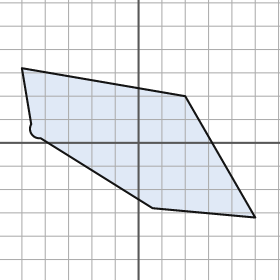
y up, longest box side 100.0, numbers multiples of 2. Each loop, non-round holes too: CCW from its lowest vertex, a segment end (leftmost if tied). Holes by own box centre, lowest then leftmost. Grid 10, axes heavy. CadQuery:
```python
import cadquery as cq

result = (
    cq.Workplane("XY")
    .moveTo(50.0, -32.0)
    .lineTo(20.0, 20.0)
    .lineTo(-50.0, 32.0)
    .lineTo(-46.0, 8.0)
    .threePointArc((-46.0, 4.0), (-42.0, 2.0))
    .lineTo(6.0, -28.0)
    .close()
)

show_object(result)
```